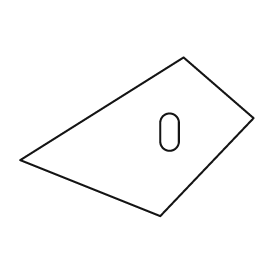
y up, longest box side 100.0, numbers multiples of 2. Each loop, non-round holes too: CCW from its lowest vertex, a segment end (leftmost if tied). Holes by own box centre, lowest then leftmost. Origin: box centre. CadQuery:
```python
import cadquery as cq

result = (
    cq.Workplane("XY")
    .moveTo(10.0, -34.0)
    .lineTo(50.0, 8.0)
    .lineTo(20.0, 34.0)
    .lineTo(-50.0, -10.0)
    .close()
    .moveTo(10.0, -2.0)
    .threePointArc((14.0, -6.0), (18.0, -2.0))
    .lineTo(18.0, 6.0)
    .threePointArc((14.0, 10.0), (10.0, 6.0))
    .close()
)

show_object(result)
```